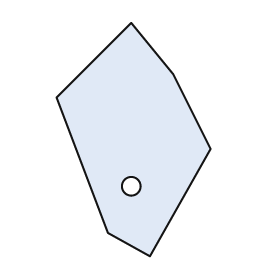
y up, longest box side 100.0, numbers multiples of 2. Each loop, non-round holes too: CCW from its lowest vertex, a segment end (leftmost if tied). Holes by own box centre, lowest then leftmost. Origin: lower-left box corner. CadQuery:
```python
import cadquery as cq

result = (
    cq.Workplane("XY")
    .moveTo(40.0, 0.0)
    .lineTo(66.0, 46.0)
    .lineTo(50.0, 78.0)
    .lineTo(32.0, 100.0)
    .lineTo(0.0, 68.0)
    .lineTo(22.0, 10.0)
    .close()
    .moveTo(32.0, 30.0)
    .circle(4.0)
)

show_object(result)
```